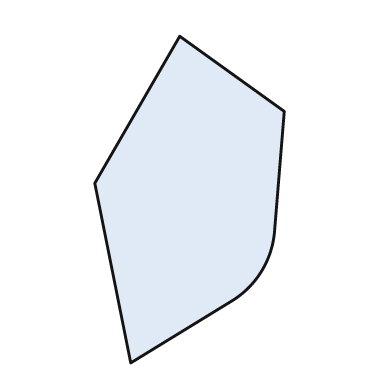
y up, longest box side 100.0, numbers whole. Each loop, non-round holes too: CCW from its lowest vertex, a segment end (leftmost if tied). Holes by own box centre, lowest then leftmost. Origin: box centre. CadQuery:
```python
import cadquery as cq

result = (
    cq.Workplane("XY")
    .moveTo(-18.0, -50.0)
    .lineTo(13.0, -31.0)
    .threePointArc((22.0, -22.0), (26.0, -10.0))
    .lineTo(29.0, 27.0)
    .lineTo(-3.0, 50.0)
    .lineTo(-29.0, 5.0)
    .close()
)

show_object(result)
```